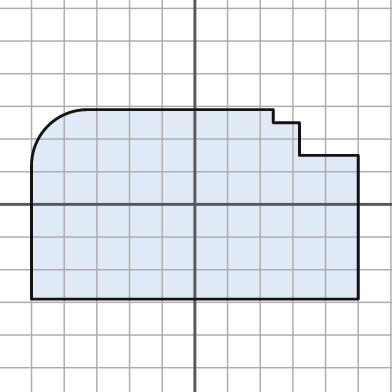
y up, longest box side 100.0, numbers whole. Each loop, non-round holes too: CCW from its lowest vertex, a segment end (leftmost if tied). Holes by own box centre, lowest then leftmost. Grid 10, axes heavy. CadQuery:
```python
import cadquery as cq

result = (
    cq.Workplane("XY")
    .moveTo(-50.0, -29.0)
    .lineTo(50.0, -29.0)
    .lineTo(50.0, 15.0)
    .lineTo(32.0, 15.0)
    .lineTo(32.0, 25.0)
    .lineTo(24.0, 25.0)
    .lineTo(24.0, 29.0)
    .lineTo(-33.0, 29.0)
    .threePointArc((-45.0, 24.0), (-50.0, 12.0))
    .close()
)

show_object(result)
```